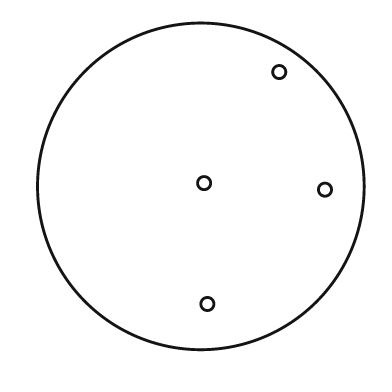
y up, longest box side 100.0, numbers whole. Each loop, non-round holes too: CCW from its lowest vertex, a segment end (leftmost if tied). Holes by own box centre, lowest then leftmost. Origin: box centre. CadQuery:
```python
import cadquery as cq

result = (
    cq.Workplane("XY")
    .moveTo(0.0, 0.0)
    .circle(50.0)
    .moveTo(2.0, -36.0)
    .circle(2.0)
    .moveTo(38.0, -1.0)
    .circle(2.0)
    .moveTo(1.0, 1.0)
    .circle(2.0)
    .moveTo(24.0, 35.0)
    .circle(2.0)
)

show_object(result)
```